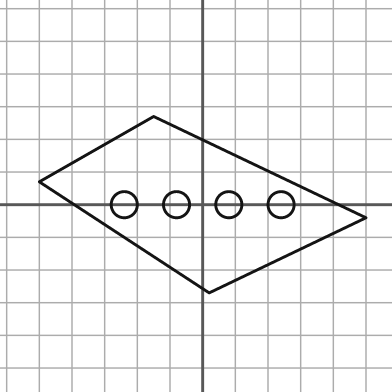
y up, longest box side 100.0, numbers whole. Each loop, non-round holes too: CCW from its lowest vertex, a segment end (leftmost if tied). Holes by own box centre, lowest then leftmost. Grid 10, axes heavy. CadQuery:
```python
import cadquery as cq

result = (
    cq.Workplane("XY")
    .moveTo(2.0, -27.0)
    .lineTo(50.0, -4.0)
    .lineTo(-15.0, 27.0)
    .lineTo(-50.0, 7.0)
    .close()
    .moveTo(-24.0, 0.0)
    .circle(4.0)
    .moveTo(-8.0, 0.0)
    .circle(4.0)
    .moveTo(8.0, 0.0)
    .circle(4.0)
    .moveTo(24.0, 0.0)
    .circle(4.0)
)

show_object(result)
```